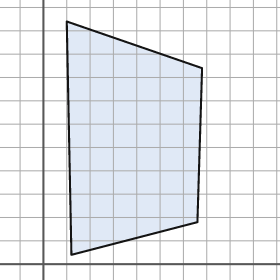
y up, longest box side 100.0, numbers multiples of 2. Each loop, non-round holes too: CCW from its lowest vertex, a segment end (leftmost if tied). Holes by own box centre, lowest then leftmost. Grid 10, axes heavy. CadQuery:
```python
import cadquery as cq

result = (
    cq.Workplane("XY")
    .moveTo(12.0, 4.0)
    .lineTo(66.0, 18.0)
    .lineTo(68.0, 84.0)
    .lineTo(10.0, 104.0)
    .close()
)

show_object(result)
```